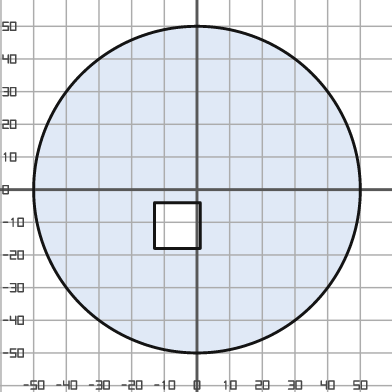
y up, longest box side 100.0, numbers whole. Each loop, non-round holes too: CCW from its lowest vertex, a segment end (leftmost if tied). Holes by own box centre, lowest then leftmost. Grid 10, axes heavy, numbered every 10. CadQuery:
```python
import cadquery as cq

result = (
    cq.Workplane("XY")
    .moveTo(0.0, 0.0)
    .circle(50.0)
    .moveTo(-13.0, -18.0)
    .lineTo(1.0, -18.0)
    .lineTo(1.0, -4.0)
    .lineTo(-13.0, -4.0)
    .close()
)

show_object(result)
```